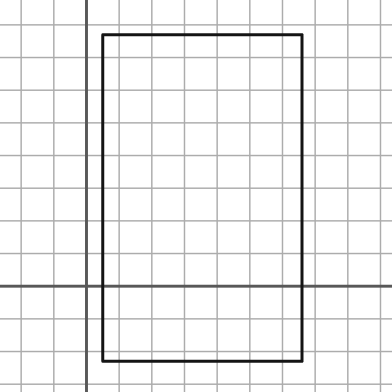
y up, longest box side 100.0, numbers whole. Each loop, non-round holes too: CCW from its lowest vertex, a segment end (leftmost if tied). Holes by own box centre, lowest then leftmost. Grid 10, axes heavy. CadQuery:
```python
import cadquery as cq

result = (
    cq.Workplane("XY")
    .moveTo(5.0, -23.0)
    .lineTo(66.0, -23.0)
    .lineTo(66.0, 77.0)
    .lineTo(5.0, 77.0)
    .close()
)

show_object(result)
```